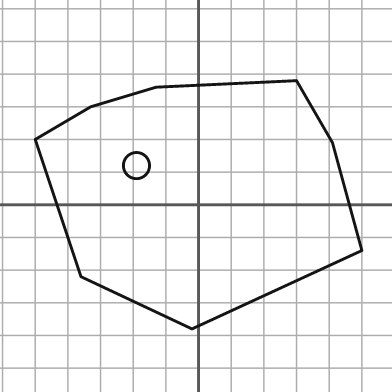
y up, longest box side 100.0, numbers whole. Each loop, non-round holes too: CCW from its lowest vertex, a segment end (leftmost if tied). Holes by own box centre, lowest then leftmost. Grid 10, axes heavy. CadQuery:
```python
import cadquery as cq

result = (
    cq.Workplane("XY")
    .moveTo(-2.0, -38.0)
    .lineTo(50.0, -14.0)
    .lineTo(41.0, 19.0)
    .lineTo(30.0, 38.0)
    .lineTo(-13.0, 36.0)
    .lineTo(-33.0, 30.0)
    .lineTo(-50.0, 20.0)
    .lineTo(-36.0, -22.0)
    .close()
    .moveTo(-19.0, 12.0)
    .circle(4.0)
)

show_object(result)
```